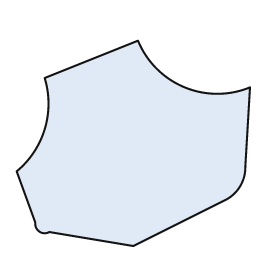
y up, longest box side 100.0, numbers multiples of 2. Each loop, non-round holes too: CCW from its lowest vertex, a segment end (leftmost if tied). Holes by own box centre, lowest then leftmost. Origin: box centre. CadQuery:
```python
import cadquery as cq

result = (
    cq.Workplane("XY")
    .moveTo(0.0, -44.0)
    .lineTo(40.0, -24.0)
    .threePointArc((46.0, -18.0), (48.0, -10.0))
    .lineTo(50.0, 24.0)
    .threePointArc((22.0, 24.0), (2.0, 44.0))
    .lineTo(-38.0, 28.0)
    .threePointArc((-38.0, 6.0), (-50.0, -12.0))
    .lineTo(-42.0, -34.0)
    .threePointArc((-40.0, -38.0), (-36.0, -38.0))
    .close()
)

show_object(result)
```